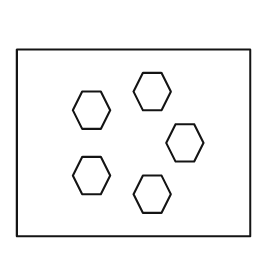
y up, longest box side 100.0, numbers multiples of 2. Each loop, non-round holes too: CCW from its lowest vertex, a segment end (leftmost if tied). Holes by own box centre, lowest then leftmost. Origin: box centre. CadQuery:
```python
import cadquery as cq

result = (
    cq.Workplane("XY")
    .moveTo(-50.0, -40.0)
    .lineTo(50.0, -40.0)
    .lineTo(50.0, 40.0)
    .lineTo(-50.0, 40.0)
    .close()
    .moveTo(4.0, -30.0)
    .lineTo(12.0, -30.0)
    .lineTo(16.0, -22.0)
    .lineTo(12.0, -14.0)
    .lineTo(4.0, -14.0)
    .lineTo(0.0, -22.0)
    .close()
    .moveTo(-22.0, -22.0)
    .lineTo(-14.0, -22.0)
    .lineTo(-10.0, -14.0)
    .lineTo(-14.0, -6.0)
    .lineTo(-22.0, -6.0)
    .lineTo(-26.0, -14.0)
    .close()
    .moveTo(18.0, -8.0)
    .lineTo(26.0, -8.0)
    .lineTo(30.0, 0.0)
    .lineTo(26.0, 8.0)
    .lineTo(18.0, 8.0)
    .lineTo(14.0, 0.0)
    .close()
    .moveTo(-22.0, 6.0)
    .lineTo(-14.0, 6.0)
    .lineTo(-10.0, 14.0)
    .lineTo(-14.0, 22.0)
    .lineTo(-22.0, 22.0)
    .lineTo(-26.0, 14.0)
    .close()
    .moveTo(4.0, 14.0)
    .lineTo(12.0, 14.0)
    .lineTo(16.0, 22.0)
    .lineTo(12.0, 30.0)
    .lineTo(4.0, 30.0)
    .lineTo(0.0, 22.0)
    .close()
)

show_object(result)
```